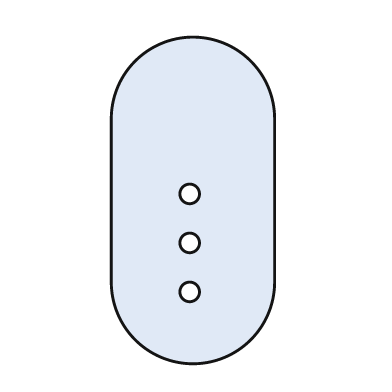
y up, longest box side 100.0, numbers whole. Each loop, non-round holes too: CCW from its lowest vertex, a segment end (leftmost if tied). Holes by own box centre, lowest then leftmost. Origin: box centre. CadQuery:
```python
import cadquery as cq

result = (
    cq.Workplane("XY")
    .moveTo(-25.0, -25.0)
    .threePointArc((0.0, -50.0), (25.0, -25.0))
    .lineTo(25.0, 25.0)
    .threePointArc((0.0, 50.0), (-25.0, 25.0))
    .close()
    .moveTo(-1.0, -28.0)
    .circle(3.0)
    .moveTo(-1.0, -13.0)
    .circle(3.0)
    .moveTo(-1.0, 2.0)
    .circle(3.0)
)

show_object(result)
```